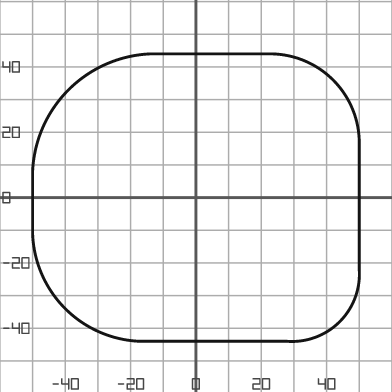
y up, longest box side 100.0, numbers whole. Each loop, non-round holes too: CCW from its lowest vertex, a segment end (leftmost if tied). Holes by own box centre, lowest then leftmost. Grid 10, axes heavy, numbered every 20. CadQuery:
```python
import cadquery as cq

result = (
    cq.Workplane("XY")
    .moveTo(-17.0, -44.0)
    .lineTo(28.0, -44.0)
    .threePointArc((44.0, -38.0), (50.0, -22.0))
    .lineTo(50.0, 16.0)
    .threePointArc((42.0, 36.0), (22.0, 44.0))
    .lineTo(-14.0, 44.0)
    .threePointArc((-39.0, 33.0), (-50.0, 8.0))
    .lineTo(-50.0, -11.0)
    .threePointArc((-40.0, -34.0), (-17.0, -44.0))
    .close()
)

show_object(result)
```